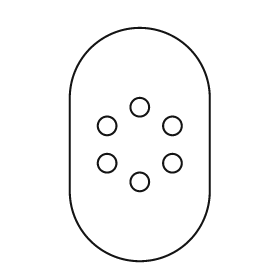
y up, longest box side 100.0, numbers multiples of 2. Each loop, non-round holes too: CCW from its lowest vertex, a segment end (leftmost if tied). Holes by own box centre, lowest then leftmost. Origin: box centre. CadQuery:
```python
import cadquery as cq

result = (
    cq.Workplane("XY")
    .moveTo(-30.0, -20.0)
    .threePointArc((0.0, -50.0), (30.0, -20.0))
    .lineTo(30.0, 20.0)
    .threePointArc((0.0, 50.0), (-30.0, 20.0))
    .close()
    .moveTo(0.0, -16.0)
    .circle(4.0)
    .moveTo(-14.0, -8.0)
    .circle(4.0)
    .moveTo(14.0, -8.0)
    .circle(4.0)
    .moveTo(-14.0, 8.0)
    .circle(4.0)
    .moveTo(14.0, 8.0)
    .circle(4.0)
    .moveTo(0.0, 16.0)
    .circle(4.0)
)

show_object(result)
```